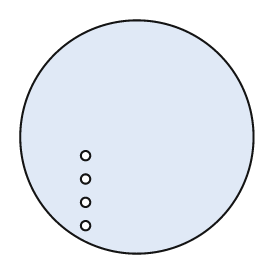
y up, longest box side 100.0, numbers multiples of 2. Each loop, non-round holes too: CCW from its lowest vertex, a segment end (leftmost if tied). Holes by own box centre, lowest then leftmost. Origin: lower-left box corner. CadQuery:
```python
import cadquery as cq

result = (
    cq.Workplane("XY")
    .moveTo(50.0, 50.0)
    .circle(50.0)
    .moveTo(28.0, 12.0)
    .circle(2.0)
    .moveTo(28.0, 22.0)
    .circle(2.0)
    .moveTo(28.0, 32.0)
    .circle(2.0)
    .moveTo(28.0, 42.0)
    .circle(2.0)
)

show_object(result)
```